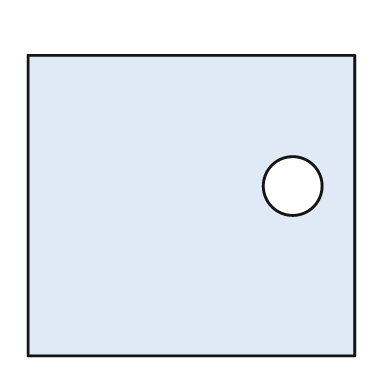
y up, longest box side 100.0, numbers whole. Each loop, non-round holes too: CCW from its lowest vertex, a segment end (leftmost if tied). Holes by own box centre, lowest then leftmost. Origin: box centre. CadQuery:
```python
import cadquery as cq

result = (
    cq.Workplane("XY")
    .moveTo(-50.0, -46.0)
    .lineTo(50.0, -46.0)
    .lineTo(50.0, 46.0)
    .lineTo(-50.0, 46.0)
    .close()
    .moveTo(31.0, 6.0)
    .circle(9.0)
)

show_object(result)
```